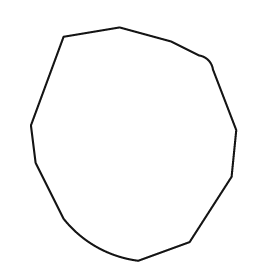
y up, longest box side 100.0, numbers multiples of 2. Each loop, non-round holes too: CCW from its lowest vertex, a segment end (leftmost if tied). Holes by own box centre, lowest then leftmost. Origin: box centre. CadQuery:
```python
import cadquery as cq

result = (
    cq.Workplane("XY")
    .moveTo(2.0, -50.0)
    .lineTo(24.0, -42.0)
    .lineTo(42.0, -14.0)
    .lineTo(44.0, 6.0)
    .lineTo(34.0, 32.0)
    .threePointArc((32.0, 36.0), (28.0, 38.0))
    .lineTo(16.0, 44.0)
    .lineTo(-6.0, 50.0)
    .lineTo(-30.0, 46.0)
    .lineTo(-44.0, 8.0)
    .lineTo(-42.0, -8.0)
    .lineTo(-30.0, -32.0)
    .threePointArc((-16.0, -44.0), (2.0, -50.0))
    .close()
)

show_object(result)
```